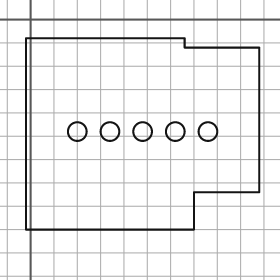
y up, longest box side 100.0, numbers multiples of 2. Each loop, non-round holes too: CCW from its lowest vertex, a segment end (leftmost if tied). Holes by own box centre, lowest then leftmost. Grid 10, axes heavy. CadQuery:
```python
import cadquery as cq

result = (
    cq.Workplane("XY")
    .moveTo(-2.0, -90.0)
    .lineTo(70.0, -90.0)
    .lineTo(70.0, -74.0)
    .lineTo(98.0, -74.0)
    .lineTo(98.0, -12.0)
    .lineTo(66.0, -12.0)
    .lineTo(66.0, -8.0)
    .lineTo(-2.0, -8.0)
    .close()
    .moveTo(20.0, -48.0)
    .circle(4.0)
    .moveTo(34.0, -48.0)
    .circle(4.0)
    .moveTo(48.0, -48.0)
    .circle(4.0)
    .moveTo(62.0, -48.0)
    .circle(4.0)
    .moveTo(76.0, -48.0)
    .circle(4.0)
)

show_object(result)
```